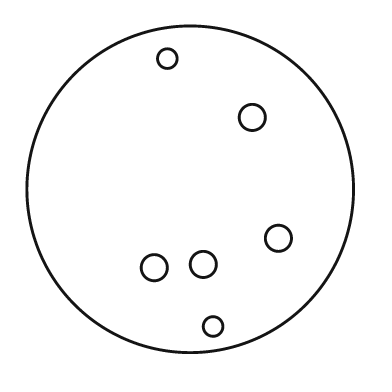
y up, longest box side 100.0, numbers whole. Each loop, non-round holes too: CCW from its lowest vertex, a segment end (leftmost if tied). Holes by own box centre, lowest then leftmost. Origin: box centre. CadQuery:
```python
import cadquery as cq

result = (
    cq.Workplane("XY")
    .moveTo(0.0, 0.0)
    .circle(50.0)
    .moveTo(7.0, -42.0)
    .circle(3.0)
    .moveTo(-11.0, -24.0)
    .circle(4.0)
    .moveTo(4.0, -23.0)
    .circle(4.0)
    .moveTo(27.0, -15.0)
    .circle(4.0)
    .moveTo(19.0, 22.0)
    .circle(4.0)
    .moveTo(-7.0, 40.0)
    .circle(3.0)
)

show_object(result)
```